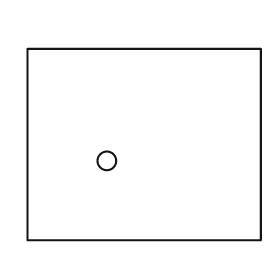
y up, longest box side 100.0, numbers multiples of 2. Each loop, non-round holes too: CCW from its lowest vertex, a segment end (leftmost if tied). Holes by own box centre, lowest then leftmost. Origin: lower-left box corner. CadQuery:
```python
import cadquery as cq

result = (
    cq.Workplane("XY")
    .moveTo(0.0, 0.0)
    .lineTo(100.0, 0.0)
    .lineTo(100.0, 82.0)
    .lineTo(0.0, 82.0)
    .close()
    .moveTo(34.0, 34.0)
    .circle(4.0)
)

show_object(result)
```